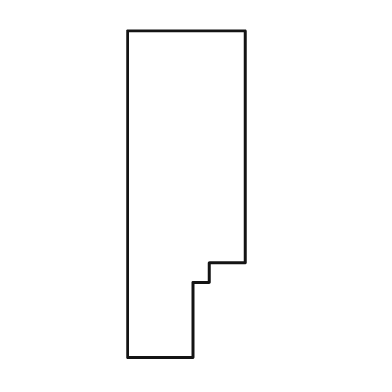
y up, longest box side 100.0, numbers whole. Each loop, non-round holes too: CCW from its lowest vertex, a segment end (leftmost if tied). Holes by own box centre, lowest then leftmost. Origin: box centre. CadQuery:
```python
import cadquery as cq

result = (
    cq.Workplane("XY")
    .moveTo(-18.0, -50.0)
    .lineTo(2.0, -50.0)
    .lineTo(2.0, -27.0)
    .lineTo(7.0, -27.0)
    .lineTo(7.0, -21.0)
    .lineTo(18.0, -21.0)
    .lineTo(18.0, 50.0)
    .lineTo(-18.0, 50.0)
    .close()
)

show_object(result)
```